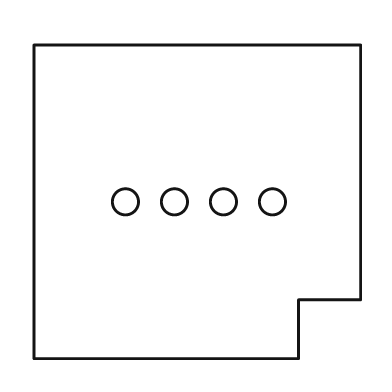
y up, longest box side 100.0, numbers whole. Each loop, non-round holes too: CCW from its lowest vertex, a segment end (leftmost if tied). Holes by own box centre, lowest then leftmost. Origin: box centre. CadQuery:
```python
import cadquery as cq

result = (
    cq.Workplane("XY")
    .moveTo(-50.0, -48.0)
    .lineTo(31.0, -48.0)
    .lineTo(31.0, -30.0)
    .lineTo(50.0, -30.0)
    .lineTo(50.0, 48.0)
    .lineTo(-50.0, 48.0)
    .close()
    .moveTo(-22.0, 0.0)
    .circle(4.0)
    .moveTo(-7.0, 0.0)
    .circle(4.0)
    .moveTo(8.0, 0.0)
    .circle(4.0)
    .moveTo(23.0, 0.0)
    .circle(4.0)
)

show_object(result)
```